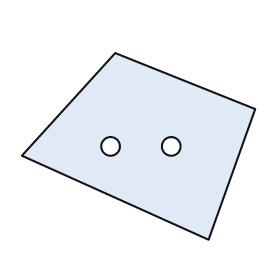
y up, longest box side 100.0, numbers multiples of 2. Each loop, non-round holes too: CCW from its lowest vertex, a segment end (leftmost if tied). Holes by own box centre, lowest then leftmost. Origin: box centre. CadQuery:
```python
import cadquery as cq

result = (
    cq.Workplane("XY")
    .moveTo(30.0, -40.0)
    .lineTo(50.0, 16.0)
    .lineTo(-10.0, 40.0)
    .lineTo(-50.0, -4.0)
    .close()
    .moveTo(-12.0, 0.0)
    .circle(4.0)
    .moveTo(14.0, 0.0)
    .circle(4.0)
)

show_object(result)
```